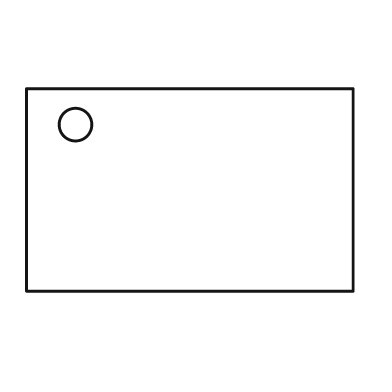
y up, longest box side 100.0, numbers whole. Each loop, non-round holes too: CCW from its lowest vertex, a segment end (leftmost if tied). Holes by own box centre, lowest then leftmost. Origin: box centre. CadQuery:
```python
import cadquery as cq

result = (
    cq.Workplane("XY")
    .moveTo(-50.0, -31.0)
    .lineTo(50.0, -31.0)
    .lineTo(50.0, 31.0)
    .lineTo(-50.0, 31.0)
    .close()
    .moveTo(-35.0, 20.0)
    .circle(5.0)
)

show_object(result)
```